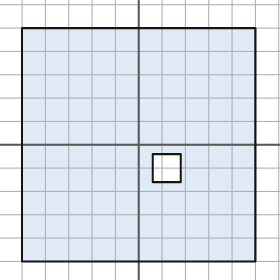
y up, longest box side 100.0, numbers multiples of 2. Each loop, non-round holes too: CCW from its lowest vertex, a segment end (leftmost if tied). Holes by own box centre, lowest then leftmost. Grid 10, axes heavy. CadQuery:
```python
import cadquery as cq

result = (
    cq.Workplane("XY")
    .moveTo(-50.0, -50.0)
    .lineTo(50.0, -50.0)
    .lineTo(50.0, 50.0)
    .lineTo(-50.0, 50.0)
    .close()
    .moveTo(6.0, -16.0)
    .lineTo(18.0, -16.0)
    .lineTo(18.0, -4.0)
    .lineTo(6.0, -4.0)
    .close()
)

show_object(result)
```